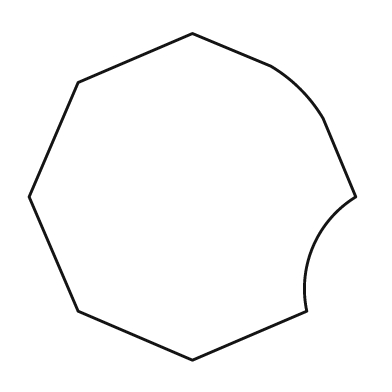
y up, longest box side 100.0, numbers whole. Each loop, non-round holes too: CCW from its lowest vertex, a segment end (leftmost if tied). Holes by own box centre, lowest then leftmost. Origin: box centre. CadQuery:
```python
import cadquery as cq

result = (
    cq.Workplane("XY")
    .moveTo(0.0, -50.0)
    .lineTo(35.0, -35.0)
    .threePointArc((37.0, -15.0), (50.0, 0.0))
    .lineTo(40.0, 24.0)
    .threePointArc((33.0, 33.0), (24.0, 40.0))
    .lineTo(0.0, 50.0)
    .lineTo(-35.0, 35.0)
    .lineTo(-50.0, 0.0)
    .lineTo(-35.0, -35.0)
    .close()
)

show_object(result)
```